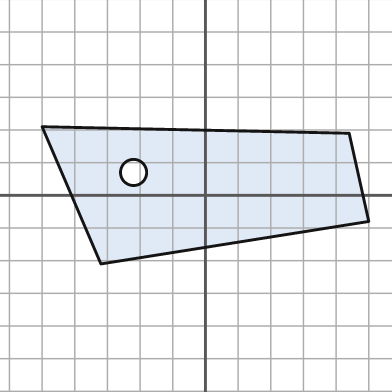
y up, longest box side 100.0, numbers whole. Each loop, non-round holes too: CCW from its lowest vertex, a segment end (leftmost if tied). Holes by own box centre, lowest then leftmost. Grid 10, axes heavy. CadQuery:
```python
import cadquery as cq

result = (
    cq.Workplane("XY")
    .moveTo(-32.0, -21.0)
    .lineTo(50.0, -8.0)
    .lineTo(44.0, 19.0)
    .lineTo(-50.0, 21.0)
    .close()
    .moveTo(-22.0, 7.0)
    .circle(4.0)
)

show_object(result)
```